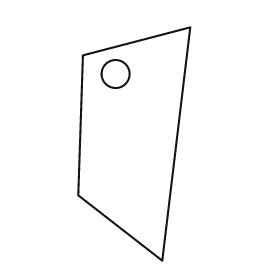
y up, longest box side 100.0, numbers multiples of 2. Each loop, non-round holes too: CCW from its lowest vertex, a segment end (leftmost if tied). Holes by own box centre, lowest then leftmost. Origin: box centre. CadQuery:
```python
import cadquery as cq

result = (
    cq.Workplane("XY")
    .moveTo(12.0, -50.0)
    .lineTo(24.0, 50.0)
    .lineTo(-22.0, 38.0)
    .lineTo(-24.0, -22.0)
    .close()
    .moveTo(-8.0, 30.0)
    .circle(6.0)
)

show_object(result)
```